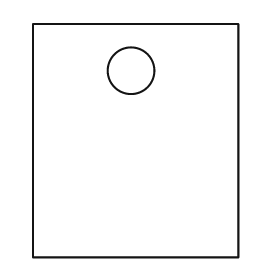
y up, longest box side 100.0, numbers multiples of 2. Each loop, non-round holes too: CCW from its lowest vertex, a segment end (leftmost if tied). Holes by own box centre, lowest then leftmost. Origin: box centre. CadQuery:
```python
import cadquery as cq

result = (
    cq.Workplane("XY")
    .moveTo(-44.0, -50.0)
    .lineTo(44.0, -50.0)
    .lineTo(44.0, 50.0)
    .lineTo(-44.0, 50.0)
    .close()
    .moveTo(-2.0, 30.0)
    .circle(10.0)
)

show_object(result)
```